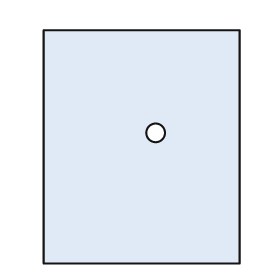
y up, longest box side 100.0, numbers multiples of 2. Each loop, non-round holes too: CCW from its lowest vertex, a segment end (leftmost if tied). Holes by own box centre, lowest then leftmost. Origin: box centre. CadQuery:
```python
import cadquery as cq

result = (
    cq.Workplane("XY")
    .moveTo(-42.0, -50.0)
    .lineTo(42.0, -50.0)
    .lineTo(42.0, 50.0)
    .lineTo(-42.0, 50.0)
    .close()
    .moveTo(6.0, 6.0)
    .circle(4.0)
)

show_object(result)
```